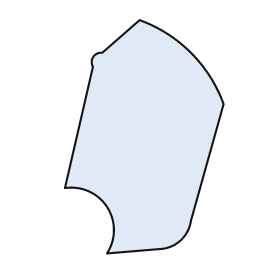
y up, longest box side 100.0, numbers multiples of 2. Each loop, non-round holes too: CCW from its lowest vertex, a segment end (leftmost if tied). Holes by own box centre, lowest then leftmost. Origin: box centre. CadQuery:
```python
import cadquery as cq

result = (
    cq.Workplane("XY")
    .moveTo(-16.0, -50.0)
    .lineTo(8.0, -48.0)
    .threePointArc((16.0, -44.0), (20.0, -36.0))
    .lineTo(34.0, 14.0)
    .threePointArc((20.0, 36.0), (-2.0, 50.0))
    .lineTo(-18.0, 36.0)
    .threePointArc((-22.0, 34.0), (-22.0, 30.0))
    .lineTo(-34.0, -22.0)
    .threePointArc((-16.0, -30.0), (-16.0, -50.0))
    .close()
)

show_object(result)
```